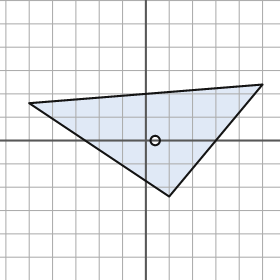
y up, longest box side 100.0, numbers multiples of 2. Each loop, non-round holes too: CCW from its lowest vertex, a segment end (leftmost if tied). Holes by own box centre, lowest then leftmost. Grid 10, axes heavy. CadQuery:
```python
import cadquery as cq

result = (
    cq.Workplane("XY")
    .moveTo(10.0, -24.0)
    .lineTo(50.0, 24.0)
    .lineTo(-50.0, 16.0)
    .close()
    .moveTo(4.0, 0.0)
    .circle(2.0)
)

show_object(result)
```